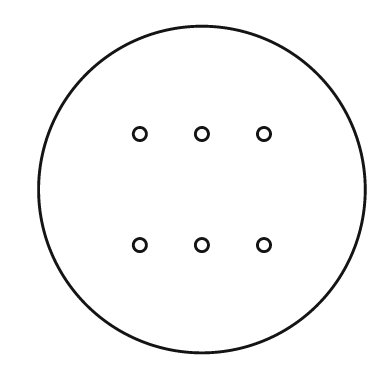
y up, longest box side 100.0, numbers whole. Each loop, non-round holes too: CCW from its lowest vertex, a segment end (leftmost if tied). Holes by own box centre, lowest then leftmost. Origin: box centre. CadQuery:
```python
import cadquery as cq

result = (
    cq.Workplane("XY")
    .moveTo(0.0, 0.0)
    .circle(50.0)
    .moveTo(-19.0, -17.0)
    .circle(2.0)
    .moveTo(0.0, -17.0)
    .circle(2.0)
    .moveTo(19.0, -17.0)
    .circle(2.0)
    .moveTo(-19.0, 17.0)
    .circle(2.0)
    .moveTo(0.0, 17.0)
    .circle(2.0)
    .moveTo(19.0, 17.0)
    .circle(2.0)
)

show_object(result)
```